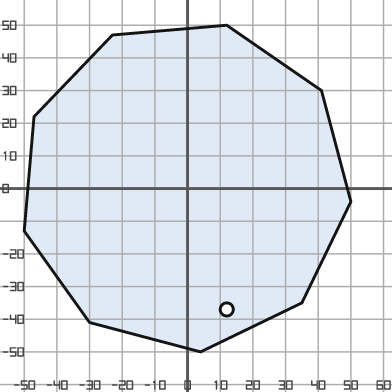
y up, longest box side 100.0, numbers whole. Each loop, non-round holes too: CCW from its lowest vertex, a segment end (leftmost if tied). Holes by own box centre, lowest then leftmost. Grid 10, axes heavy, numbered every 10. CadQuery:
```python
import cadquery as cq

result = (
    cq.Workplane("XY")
    .moveTo(4.0, -50.0)
    .lineTo(35.0, -35.0)
    .lineTo(50.0, -4.0)
    .lineTo(41.0, 30.0)
    .lineTo(12.0, 50.0)
    .lineTo(-23.0, 47.0)
    .lineTo(-47.0, 22.0)
    .lineTo(-50.0, -13.0)
    .lineTo(-30.0, -41.0)
    .close()
    .moveTo(12.0, -37.0)
    .circle(2.0)
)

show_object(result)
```